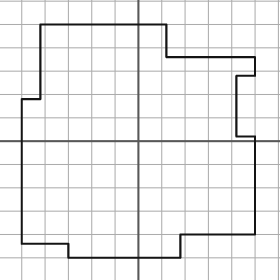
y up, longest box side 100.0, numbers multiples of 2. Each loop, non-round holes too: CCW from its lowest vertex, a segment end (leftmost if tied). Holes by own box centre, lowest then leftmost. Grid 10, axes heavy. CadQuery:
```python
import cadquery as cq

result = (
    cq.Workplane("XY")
    .moveTo(-30.0, -50.0)
    .lineTo(18.0, -50.0)
    .lineTo(18.0, -40.0)
    .lineTo(50.0, -40.0)
    .lineTo(50.0, 2.0)
    .lineTo(42.0, 2.0)
    .lineTo(42.0, 28.0)
    .lineTo(50.0, 28.0)
    .lineTo(50.0, 36.0)
    .lineTo(12.0, 36.0)
    .lineTo(12.0, 50.0)
    .lineTo(-42.0, 50.0)
    .lineTo(-42.0, 18.0)
    .lineTo(-50.0, 18.0)
    .lineTo(-50.0, -44.0)
    .lineTo(-30.0, -44.0)
    .close()
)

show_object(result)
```